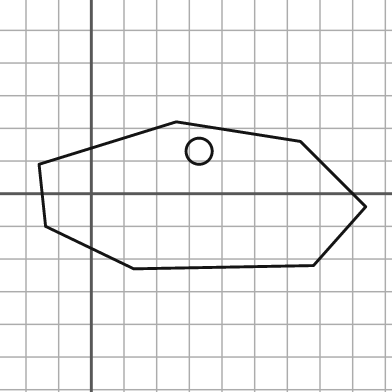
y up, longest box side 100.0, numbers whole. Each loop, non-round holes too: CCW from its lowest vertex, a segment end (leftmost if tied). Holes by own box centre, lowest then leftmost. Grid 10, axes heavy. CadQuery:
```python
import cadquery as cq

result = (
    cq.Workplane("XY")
    .moveTo(13.0, -23.0)
    .lineTo(68.0, -22.0)
    .lineTo(84.0, -4.0)
    .lineTo(64.0, 16.0)
    .lineTo(26.0, 22.0)
    .lineTo(-16.0, 9.0)
    .lineTo(-14.0, -10.0)
    .close()
    .moveTo(33.0, 13.0)
    .circle(4.0)
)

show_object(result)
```